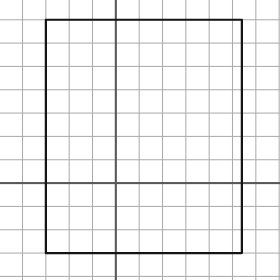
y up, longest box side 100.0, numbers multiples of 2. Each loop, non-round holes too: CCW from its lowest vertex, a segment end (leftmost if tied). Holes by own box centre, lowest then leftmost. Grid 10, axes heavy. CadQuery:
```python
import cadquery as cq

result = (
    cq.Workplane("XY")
    .moveTo(-30.0, -30.0)
    .lineTo(54.0, -30.0)
    .lineTo(54.0, 70.0)
    .lineTo(-30.0, 70.0)
    .close()
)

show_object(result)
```